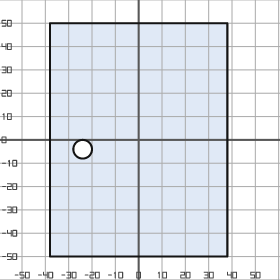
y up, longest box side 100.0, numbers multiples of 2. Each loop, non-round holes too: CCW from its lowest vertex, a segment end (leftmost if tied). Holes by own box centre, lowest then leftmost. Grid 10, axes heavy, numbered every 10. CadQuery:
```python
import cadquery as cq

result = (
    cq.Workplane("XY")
    .moveTo(-38.0, -50.0)
    .lineTo(38.0, -50.0)
    .lineTo(38.0, 50.0)
    .lineTo(-38.0, 50.0)
    .close()
    .moveTo(-24.0, -4.0)
    .circle(4.0)
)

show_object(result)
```